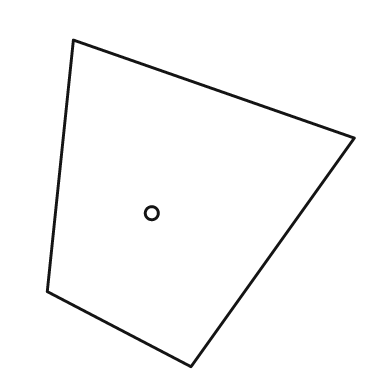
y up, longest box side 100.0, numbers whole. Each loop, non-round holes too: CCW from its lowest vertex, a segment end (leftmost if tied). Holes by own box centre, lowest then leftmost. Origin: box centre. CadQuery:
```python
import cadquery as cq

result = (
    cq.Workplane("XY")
    .moveTo(-3.0, -50.0)
    .lineTo(47.0, 20.0)
    .lineTo(-39.0, 50.0)
    .lineTo(-47.0, -27.0)
    .close()
    .moveTo(-15.0, -3.0)
    .circle(2.0)
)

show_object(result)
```